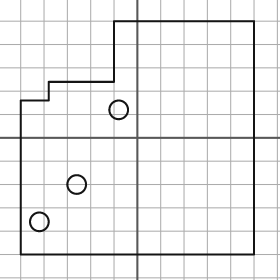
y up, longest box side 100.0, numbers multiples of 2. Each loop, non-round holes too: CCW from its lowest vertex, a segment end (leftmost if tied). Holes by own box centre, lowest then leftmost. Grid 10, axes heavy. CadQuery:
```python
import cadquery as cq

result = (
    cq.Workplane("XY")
    .moveTo(-50.0, -50.0)
    .lineTo(50.0, -50.0)
    .lineTo(50.0, 50.0)
    .lineTo(-10.0, 50.0)
    .lineTo(-10.0, 24.0)
    .lineTo(-38.0, 24.0)
    .lineTo(-38.0, 16.0)
    .lineTo(-50.0, 16.0)
    .close()
    .moveTo(-42.0, -36.0)
    .circle(4.0)
    .moveTo(-26.0, -20.0)
    .circle(4.0)
    .moveTo(-8.0, 12.0)
    .circle(4.0)
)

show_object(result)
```